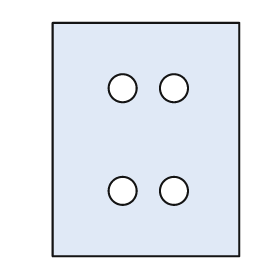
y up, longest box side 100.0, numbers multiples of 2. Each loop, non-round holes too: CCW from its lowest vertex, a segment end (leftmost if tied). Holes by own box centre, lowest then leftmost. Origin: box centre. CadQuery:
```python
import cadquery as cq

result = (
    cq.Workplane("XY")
    .moveTo(-40.0, -50.0)
    .lineTo(40.0, -50.0)
    .lineTo(40.0, 50.0)
    .lineTo(-40.0, 50.0)
    .close()
    .moveTo(-10.0, -22.0)
    .circle(6.0)
    .moveTo(12.0, -22.0)
    .circle(6.0)
    .moveTo(-10.0, 22.0)
    .circle(6.0)
    .moveTo(12.0, 22.0)
    .circle(6.0)
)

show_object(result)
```